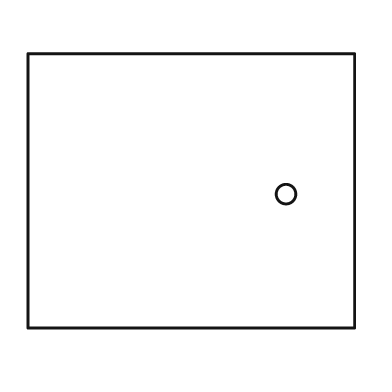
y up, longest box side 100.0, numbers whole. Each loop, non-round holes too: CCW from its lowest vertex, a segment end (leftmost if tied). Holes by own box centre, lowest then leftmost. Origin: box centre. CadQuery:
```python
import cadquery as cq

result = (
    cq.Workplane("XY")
    .moveTo(-50.0, -42.0)
    .lineTo(50.0, -42.0)
    .lineTo(50.0, 42.0)
    .lineTo(-50.0, 42.0)
    .close()
    .moveTo(29.0, -1.0)
    .circle(3.0)
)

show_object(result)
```